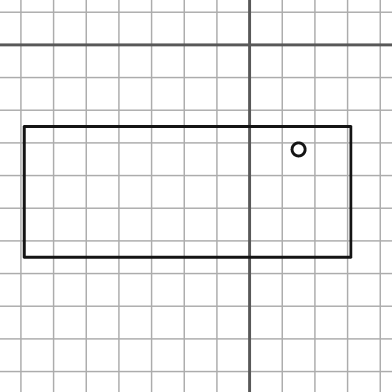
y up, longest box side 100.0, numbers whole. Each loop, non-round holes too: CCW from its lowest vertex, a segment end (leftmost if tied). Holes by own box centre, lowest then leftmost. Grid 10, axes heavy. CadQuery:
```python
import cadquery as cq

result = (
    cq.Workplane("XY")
    .moveTo(-69.0, -65.0)
    .lineTo(31.0, -65.0)
    .lineTo(31.0, -25.0)
    .lineTo(-69.0, -25.0)
    .close()
    .moveTo(15.0, -32.0)
    .circle(2.0)
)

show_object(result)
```